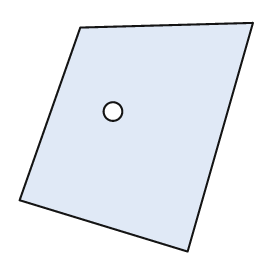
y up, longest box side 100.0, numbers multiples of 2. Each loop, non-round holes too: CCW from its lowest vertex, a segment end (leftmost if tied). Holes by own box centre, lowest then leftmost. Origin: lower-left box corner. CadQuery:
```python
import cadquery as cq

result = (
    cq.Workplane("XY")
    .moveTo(72.0, 0.0)
    .lineTo(100.0, 98.0)
    .lineTo(26.0, 96.0)
    .lineTo(0.0, 22.0)
    .close()
    .moveTo(40.0, 60.0)
    .circle(4.0)
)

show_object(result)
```